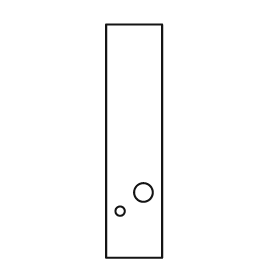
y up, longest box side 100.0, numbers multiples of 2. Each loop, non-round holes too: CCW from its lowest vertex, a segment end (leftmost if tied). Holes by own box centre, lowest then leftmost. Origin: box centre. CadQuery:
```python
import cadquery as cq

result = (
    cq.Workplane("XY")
    .moveTo(-12.0, -50.0)
    .lineTo(12.0, -50.0)
    .lineTo(12.0, 50.0)
    .lineTo(-12.0, 50.0)
    .close()
    .moveTo(-6.0, -30.0)
    .circle(2.0)
    .moveTo(4.0, -22.0)
    .circle(4.0)
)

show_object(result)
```